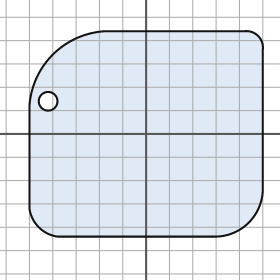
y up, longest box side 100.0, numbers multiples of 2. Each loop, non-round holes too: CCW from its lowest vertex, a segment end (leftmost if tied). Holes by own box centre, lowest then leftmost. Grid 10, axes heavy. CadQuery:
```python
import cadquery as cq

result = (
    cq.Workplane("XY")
    .moveTo(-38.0, -44.0)
    .lineTo(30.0, -44.0)
    .threePointArc((44.0, -38.0), (50.0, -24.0))
    .lineTo(50.0, 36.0)
    .threePointArc((48.0, 42.0), (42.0, 44.0))
    .lineTo(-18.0, 44.0)
    .threePointArc((-40.0, 34.0), (-50.0, 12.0))
    .lineTo(-50.0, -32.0)
    .threePointArc((-46.0, -40.0), (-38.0, -44.0))
    .close()
    .moveTo(-42.0, 14.0)
    .circle(4.0)
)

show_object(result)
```